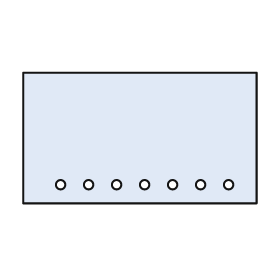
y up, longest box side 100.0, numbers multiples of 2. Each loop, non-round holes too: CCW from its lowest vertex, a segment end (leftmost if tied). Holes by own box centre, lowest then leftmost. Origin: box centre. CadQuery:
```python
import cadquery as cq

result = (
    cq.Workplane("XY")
    .moveTo(-50.0, -28.0)
    .lineTo(50.0, -28.0)
    .lineTo(50.0, 28.0)
    .lineTo(-50.0, 28.0)
    .close()
    .moveTo(-34.0, -20.0)
    .circle(2.0)
    .moveTo(-22.0, -20.0)
    .circle(2.0)
    .moveTo(-10.0, -20.0)
    .circle(2.0)
    .moveTo(2.0, -20.0)
    .circle(2.0)
    .moveTo(14.0, -20.0)
    .circle(2.0)
    .moveTo(26.0, -20.0)
    .circle(2.0)
    .moveTo(38.0, -20.0)
    .circle(2.0)
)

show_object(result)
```